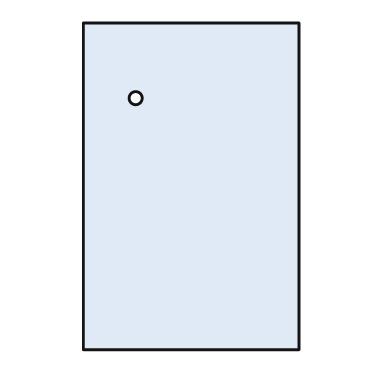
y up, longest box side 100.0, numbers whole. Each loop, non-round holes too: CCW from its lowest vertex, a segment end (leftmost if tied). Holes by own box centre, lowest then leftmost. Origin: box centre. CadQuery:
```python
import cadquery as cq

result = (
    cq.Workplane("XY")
    .moveTo(-33.0, -50.0)
    .lineTo(33.0, -50.0)
    .lineTo(33.0, 50.0)
    .lineTo(-33.0, 50.0)
    .close()
    .moveTo(-17.0, 27.0)
    .circle(2.0)
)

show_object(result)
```